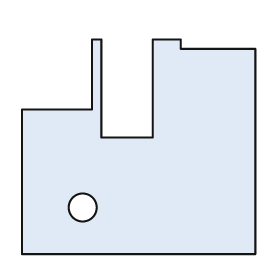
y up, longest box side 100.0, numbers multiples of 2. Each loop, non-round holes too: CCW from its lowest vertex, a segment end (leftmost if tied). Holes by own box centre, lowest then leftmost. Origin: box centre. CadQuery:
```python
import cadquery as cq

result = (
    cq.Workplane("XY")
    .moveTo(-50.0, -46.0)
    .lineTo(50.0, -46.0)
    .lineTo(50.0, 42.0)
    .lineTo(18.0, 42.0)
    .lineTo(18.0, 46.0)
    .lineTo(6.0, 46.0)
    .lineTo(6.0, 4.0)
    .lineTo(-16.0, 4.0)
    .lineTo(-16.0, 46.0)
    .lineTo(-20.0, 46.0)
    .lineTo(-20.0, 16.0)
    .lineTo(-50.0, 16.0)
    .close()
    .moveTo(-24.0, -26.0)
    .circle(6.0)
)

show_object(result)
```